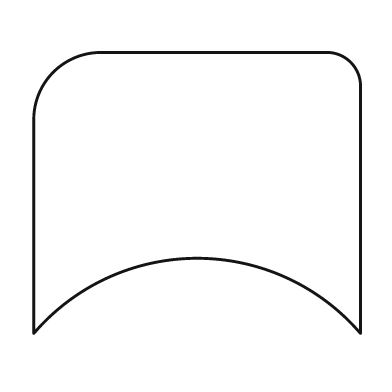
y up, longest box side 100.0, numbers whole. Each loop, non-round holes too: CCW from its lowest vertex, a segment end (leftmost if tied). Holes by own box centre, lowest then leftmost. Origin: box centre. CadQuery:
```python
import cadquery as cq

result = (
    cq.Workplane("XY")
    .moveTo(-50.0, -43.0)
    .threePointArc((0.0, -20.0), (50.0, -43.0))
    .lineTo(50.0, 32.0)
    .threePointArc((47.0, 40.0), (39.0, 43.0))
    .lineTo(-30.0, 43.0)
    .threePointArc((-44.0, 37.0), (-50.0, 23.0))
    .close()
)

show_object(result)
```